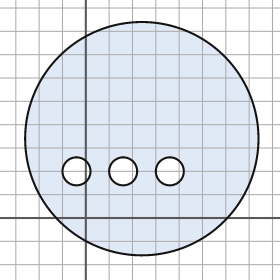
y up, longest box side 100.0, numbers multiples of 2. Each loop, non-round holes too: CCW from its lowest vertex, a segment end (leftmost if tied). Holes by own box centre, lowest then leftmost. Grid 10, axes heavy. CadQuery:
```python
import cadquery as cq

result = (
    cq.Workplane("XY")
    .moveTo(24.0, 34.0)
    .circle(50.0)
    .moveTo(-4.0, 20.0)
    .circle(6.0)
    .moveTo(16.0, 20.0)
    .circle(6.0)
    .moveTo(36.0, 20.0)
    .circle(6.0)
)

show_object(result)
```